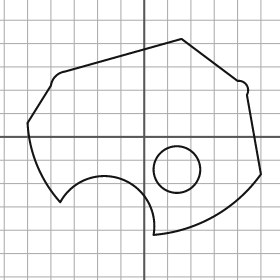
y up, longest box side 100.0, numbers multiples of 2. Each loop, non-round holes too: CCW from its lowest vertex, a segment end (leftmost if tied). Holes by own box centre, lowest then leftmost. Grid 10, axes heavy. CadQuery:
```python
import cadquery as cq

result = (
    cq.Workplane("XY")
    .moveTo(4.0, -42.0)
    .threePointArc((30.0, -34.0), (50.0, -16.0))
    .lineTo(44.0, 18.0)
    .threePointArc((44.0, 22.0), (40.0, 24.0))
    .lineTo(16.0, 42.0)
    .lineTo(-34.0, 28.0)
    .threePointArc((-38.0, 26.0), (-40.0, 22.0))
    .lineTo(-50.0, 6.0)
    .threePointArc((-46.0, -12.0), (-36.0, -28.0))
    .threePointArc((-10.0, -18.0), (4.0, -42.0))
    .close()
    .moveTo(14.0, -14.0)
    .circle(10.0)
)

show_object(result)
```